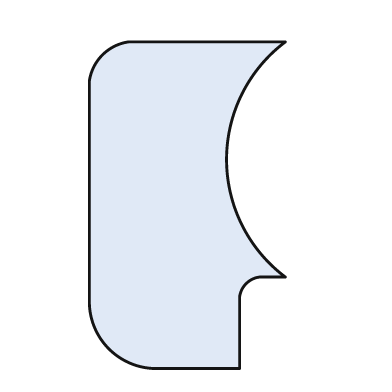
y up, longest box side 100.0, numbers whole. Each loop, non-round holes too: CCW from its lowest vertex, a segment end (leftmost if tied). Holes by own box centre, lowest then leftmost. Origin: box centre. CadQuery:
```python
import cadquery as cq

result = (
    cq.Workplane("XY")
    .moveTo(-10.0, -50.0)
    .lineTo(16.0, -50.0)
    .lineTo(16.0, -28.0)
    .threePointArc((18.0, -24.0), (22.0, -22.0))
    .lineTo(30.0, -22.0)
    .threePointArc((12.0, 14.0), (30.0, 50.0))
    .lineTo(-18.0, 50.0)
    .threePointArc((-26.0, 46.0), (-30.0, 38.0))
    .lineTo(-30.0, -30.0)
    .threePointArc((-24.0, -44.0), (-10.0, -50.0))
    .close()
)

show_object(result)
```